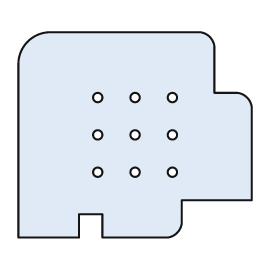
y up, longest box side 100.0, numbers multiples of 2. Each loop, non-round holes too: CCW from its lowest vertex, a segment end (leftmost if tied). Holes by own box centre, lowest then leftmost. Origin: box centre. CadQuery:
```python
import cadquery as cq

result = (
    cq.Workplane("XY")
    .moveTo(-50.0, -44.0)
    .lineTo(-24.0, -44.0)
    .lineTo(-24.0, -34.0)
    .lineTo(-14.0, -34.0)
    .lineTo(-14.0, -44.0)
    .lineTo(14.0, -44.0)
    .threePointArc((18.0, -42.0), (20.0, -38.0))
    .lineTo(20.0, -28.0)
    .lineTo(50.0, -28.0)
    .lineTo(50.0, 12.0)
    .threePointArc((48.0, 16.0), (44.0, 18.0))
    .lineTo(34.0, 18.0)
    .lineTo(34.0, 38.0)
    .threePointArc((32.0, 42.0), (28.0, 44.0))
    .lineTo(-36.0, 44.0)
    .threePointArc((-46.0, 40.0), (-50.0, 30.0))
    .close()
    .moveTo(-16.0, -16.0)
    .circle(2.0)
    .moveTo(0.0, -16.0)
    .circle(2.0)
    .moveTo(16.0, -16.0)
    .circle(2.0)
    .moveTo(-16.0, 0.0)
    .circle(2.0)
    .moveTo(0.0, 0.0)
    .circle(2.0)
    .moveTo(16.0, 0.0)
    .circle(2.0)
    .moveTo(-16.0, 16.0)
    .circle(2.0)
    .moveTo(0.0, 16.0)
    .circle(2.0)
    .moveTo(16.0, 16.0)
    .circle(2.0)
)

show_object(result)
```